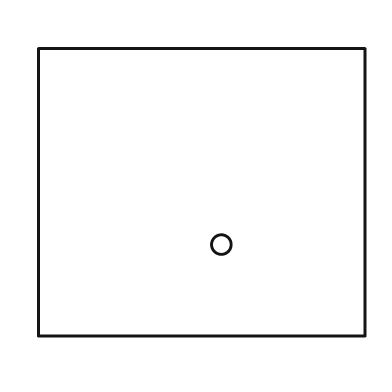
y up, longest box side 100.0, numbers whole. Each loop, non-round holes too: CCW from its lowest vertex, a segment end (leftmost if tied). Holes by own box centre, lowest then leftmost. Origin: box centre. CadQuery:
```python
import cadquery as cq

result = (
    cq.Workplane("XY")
    .moveTo(-50.0, -44.0)
    .lineTo(50.0, -44.0)
    .lineTo(50.0, 44.0)
    .lineTo(-50.0, 44.0)
    .close()
    .moveTo(6.0, -16.0)
    .circle(3.0)
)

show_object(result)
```